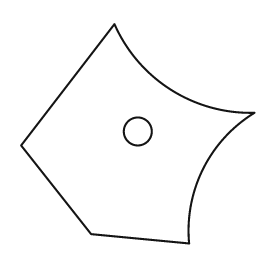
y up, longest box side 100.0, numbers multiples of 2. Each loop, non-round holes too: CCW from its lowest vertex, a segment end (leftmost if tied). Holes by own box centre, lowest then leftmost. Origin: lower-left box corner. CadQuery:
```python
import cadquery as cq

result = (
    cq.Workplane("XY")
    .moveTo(72.0, 0.0)
    .threePointArc((78.0, 32.0), (100.0, 56.0))
    .threePointArc((64.0, 66.0), (40.0, 94.0))
    .lineTo(0.0, 42.0)
    .lineTo(30.0, 4.0)
    .close()
    .moveTo(50.0, 48.0)
    .circle(6.0)
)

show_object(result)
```